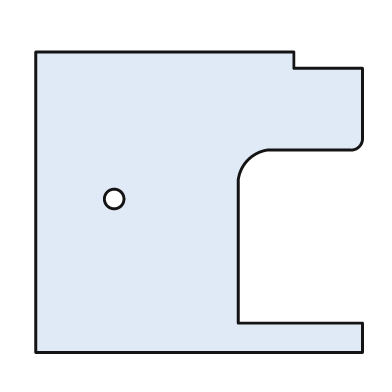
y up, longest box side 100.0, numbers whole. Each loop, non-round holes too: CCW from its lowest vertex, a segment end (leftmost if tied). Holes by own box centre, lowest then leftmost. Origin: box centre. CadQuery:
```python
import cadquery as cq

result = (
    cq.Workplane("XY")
    .moveTo(-50.0, -46.0)
    .lineTo(50.0, -46.0)
    .lineTo(50.0, -37.0)
    .lineTo(12.0, -37.0)
    .lineTo(12.0, 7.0)
    .threePointArc((15.0, 13.0), (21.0, 16.0))
    .lineTo(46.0, 16.0)
    .threePointArc((49.0, 17.0), (50.0, 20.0))
    .lineTo(50.0, 41.0)
    .lineTo(29.0, 41.0)
    .lineTo(29.0, 46.0)
    .lineTo(-50.0, 46.0)
    .close()
    .moveTo(-26.0, 1.0)
    .circle(3.0)
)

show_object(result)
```